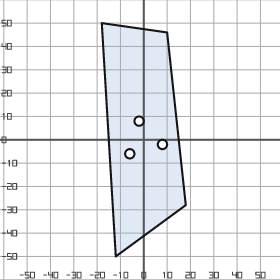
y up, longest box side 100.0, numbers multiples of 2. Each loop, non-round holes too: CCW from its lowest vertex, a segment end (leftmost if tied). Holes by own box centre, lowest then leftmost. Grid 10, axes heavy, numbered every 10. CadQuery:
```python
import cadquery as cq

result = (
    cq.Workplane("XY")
    .moveTo(-12.0, -50.0)
    .lineTo(18.0, -28.0)
    .lineTo(10.0, 46.0)
    .lineTo(-18.0, 50.0)
    .close()
    .moveTo(-6.0, -6.0)
    .circle(2.0)
    .moveTo(8.0, -2.0)
    .circle(2.0)
    .moveTo(-2.0, 8.0)
    .circle(2.0)
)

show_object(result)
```